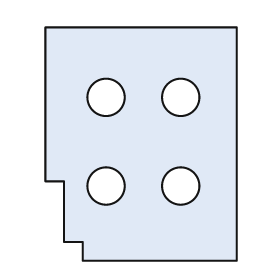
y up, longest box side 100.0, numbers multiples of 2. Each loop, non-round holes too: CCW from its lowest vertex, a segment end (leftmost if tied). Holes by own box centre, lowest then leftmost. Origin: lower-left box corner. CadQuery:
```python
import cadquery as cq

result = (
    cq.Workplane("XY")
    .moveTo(16.0, 0.0)
    .lineTo(82.0, 0.0)
    .lineTo(82.0, 100.0)
    .lineTo(0.0, 100.0)
    .lineTo(0.0, 34.0)
    .lineTo(8.0, 34.0)
    .lineTo(8.0, 8.0)
    .lineTo(16.0, 8.0)
    .close()
    .moveTo(26.0, 32.0)
    .circle(8.0)
    .moveTo(58.0, 32.0)
    .circle(8.0)
    .moveTo(26.0, 70.0)
    .circle(8.0)
    .moveTo(58.0, 70.0)
    .circle(8.0)
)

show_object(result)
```